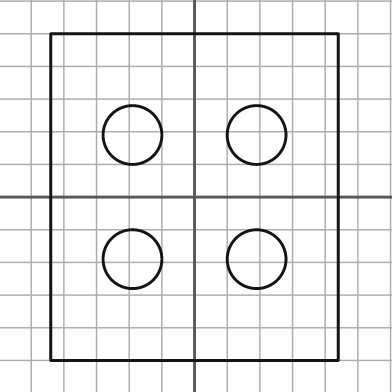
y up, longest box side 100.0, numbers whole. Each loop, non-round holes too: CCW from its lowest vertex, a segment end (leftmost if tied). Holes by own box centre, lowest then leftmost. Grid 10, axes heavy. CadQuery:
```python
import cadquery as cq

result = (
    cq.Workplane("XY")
    .moveTo(-44.0, -50.0)
    .lineTo(44.0, -50.0)
    .lineTo(44.0, 50.0)
    .lineTo(-44.0, 50.0)
    .close()
    .moveTo(-19.0, -19.0)
    .circle(9.0)
    .moveTo(19.0, -19.0)
    .circle(9.0)
    .moveTo(-19.0, 19.0)
    .circle(9.0)
    .moveTo(19.0, 19.0)
    .circle(9.0)
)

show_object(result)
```